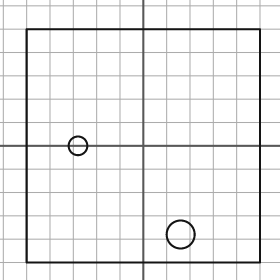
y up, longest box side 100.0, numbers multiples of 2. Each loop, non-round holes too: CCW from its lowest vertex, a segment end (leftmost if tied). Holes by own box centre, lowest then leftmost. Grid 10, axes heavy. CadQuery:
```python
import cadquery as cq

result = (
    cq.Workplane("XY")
    .moveTo(-50.0, -50.0)
    .lineTo(50.0, -50.0)
    .lineTo(50.0, 50.0)
    .lineTo(-50.0, 50.0)
    .close()
    .moveTo(16.0, -38.0)
    .circle(6.0)
    .moveTo(-28.0, 0.0)
    .circle(4.0)
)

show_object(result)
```